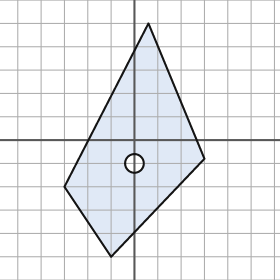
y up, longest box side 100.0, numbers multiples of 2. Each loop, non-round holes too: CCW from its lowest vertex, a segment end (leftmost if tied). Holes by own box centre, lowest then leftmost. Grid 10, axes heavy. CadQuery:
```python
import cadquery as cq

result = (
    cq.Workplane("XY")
    .moveTo(-10.0, -50.0)
    .lineTo(30.0, -8.0)
    .lineTo(6.0, 50.0)
    .lineTo(-30.0, -20.0)
    .close()
    .moveTo(0.0, -10.0)
    .circle(4.0)
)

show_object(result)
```